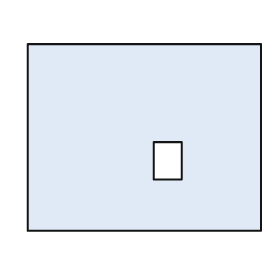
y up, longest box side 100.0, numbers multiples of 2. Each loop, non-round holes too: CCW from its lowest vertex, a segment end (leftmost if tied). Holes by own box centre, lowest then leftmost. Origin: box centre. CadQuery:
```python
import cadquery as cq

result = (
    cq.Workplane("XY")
    .moveTo(-50.0, -40.0)
    .lineTo(50.0, -40.0)
    .lineTo(50.0, 40.0)
    .lineTo(-50.0, 40.0)
    .close()
    .moveTo(4.0, -18.0)
    .lineTo(16.0, -18.0)
    .lineTo(16.0, -2.0)
    .lineTo(4.0, -2.0)
    .close()
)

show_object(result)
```